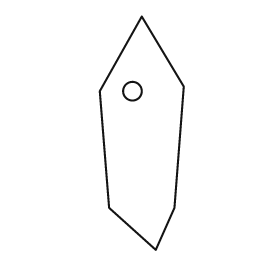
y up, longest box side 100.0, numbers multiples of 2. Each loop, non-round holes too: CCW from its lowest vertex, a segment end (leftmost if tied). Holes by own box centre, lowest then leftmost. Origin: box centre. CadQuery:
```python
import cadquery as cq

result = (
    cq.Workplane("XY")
    .moveTo(6.0, -50.0)
    .lineTo(14.0, -32.0)
    .lineTo(18.0, 20.0)
    .lineTo(0.0, 50.0)
    .lineTo(-18.0, 18.0)
    .lineTo(-14.0, -32.0)
    .close()
    .moveTo(-4.0, 18.0)
    .circle(4.0)
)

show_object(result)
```